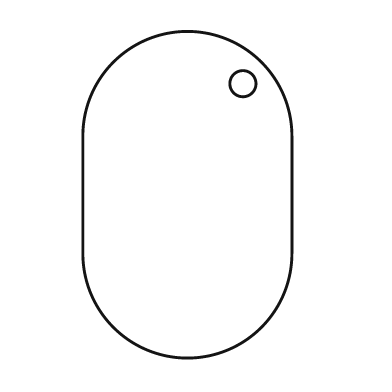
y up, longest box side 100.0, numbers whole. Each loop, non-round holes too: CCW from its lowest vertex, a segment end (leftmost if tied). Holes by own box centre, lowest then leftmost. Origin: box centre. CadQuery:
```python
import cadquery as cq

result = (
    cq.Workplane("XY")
    .moveTo(-32.0, -18.0)
    .threePointArc((0.0, -50.0), (32.0, -18.0))
    .lineTo(32.0, 18.0)
    .threePointArc((0.0, 50.0), (-32.0, 18.0))
    .close()
    .moveTo(17.0, 34.0)
    .circle(4.0)
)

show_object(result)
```